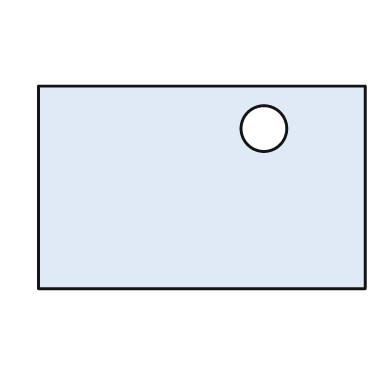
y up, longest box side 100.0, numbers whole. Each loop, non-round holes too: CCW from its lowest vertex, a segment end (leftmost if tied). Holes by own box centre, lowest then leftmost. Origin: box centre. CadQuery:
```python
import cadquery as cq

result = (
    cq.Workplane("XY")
    .moveTo(-50.0, -31.0)
    .lineTo(50.0, -31.0)
    .lineTo(50.0, 31.0)
    .lineTo(-50.0, 31.0)
    .close()
    .moveTo(19.0, 18.0)
    .circle(7.0)
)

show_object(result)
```